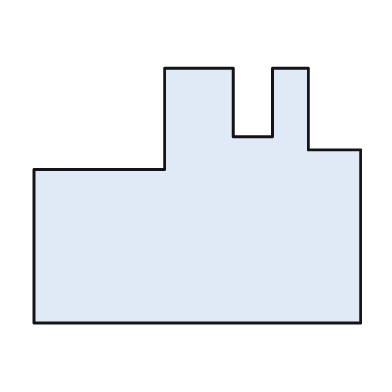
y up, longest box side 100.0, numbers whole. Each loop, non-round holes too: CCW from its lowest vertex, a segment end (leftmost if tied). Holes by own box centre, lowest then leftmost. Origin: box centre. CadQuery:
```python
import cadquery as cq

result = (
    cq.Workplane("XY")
    .moveTo(-50.0, -39.0)
    .lineTo(50.0, -39.0)
    .lineTo(50.0, 14.0)
    .lineTo(34.0, 14.0)
    .lineTo(34.0, 39.0)
    .lineTo(23.0, 39.0)
    .lineTo(23.0, 18.0)
    .lineTo(11.0, 18.0)
    .lineTo(11.0, 39.0)
    .lineTo(-10.0, 39.0)
    .lineTo(-10.0, 8.0)
    .lineTo(-50.0, 8.0)
    .close()
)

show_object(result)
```